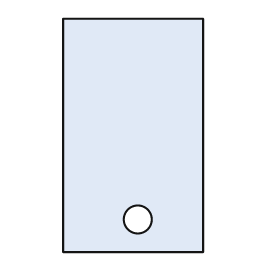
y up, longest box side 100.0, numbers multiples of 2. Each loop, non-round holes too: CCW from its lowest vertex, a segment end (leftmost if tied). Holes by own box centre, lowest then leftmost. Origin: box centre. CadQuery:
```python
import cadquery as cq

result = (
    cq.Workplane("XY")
    .moveTo(-30.0, -50.0)
    .lineTo(30.0, -50.0)
    .lineTo(30.0, 50.0)
    .lineTo(-30.0, 50.0)
    .close()
    .moveTo(2.0, -36.0)
    .circle(6.0)
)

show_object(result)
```